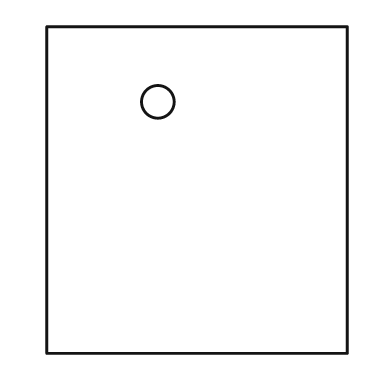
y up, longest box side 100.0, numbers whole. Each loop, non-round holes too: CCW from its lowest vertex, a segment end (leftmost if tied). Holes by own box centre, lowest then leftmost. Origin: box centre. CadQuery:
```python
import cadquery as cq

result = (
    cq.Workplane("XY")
    .moveTo(-46.0, -50.0)
    .lineTo(46.0, -50.0)
    .lineTo(46.0, 50.0)
    .lineTo(-46.0, 50.0)
    .close()
    .moveTo(-12.0, 27.0)
    .circle(5.0)
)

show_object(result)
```